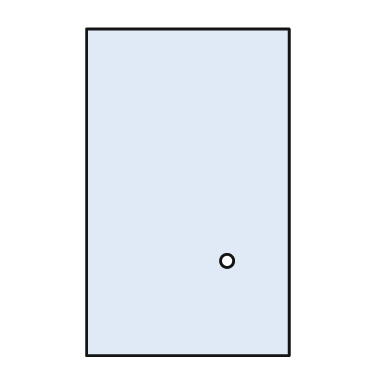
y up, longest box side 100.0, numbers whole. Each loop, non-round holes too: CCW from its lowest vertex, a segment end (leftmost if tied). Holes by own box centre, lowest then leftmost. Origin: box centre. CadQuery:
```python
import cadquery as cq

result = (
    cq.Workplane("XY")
    .moveTo(-31.0, -50.0)
    .lineTo(31.0, -50.0)
    .lineTo(31.0, 50.0)
    .lineTo(-31.0, 50.0)
    .close()
    .moveTo(12.0, -21.0)
    .circle(2.0)
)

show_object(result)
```